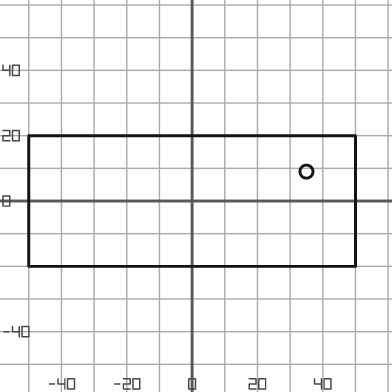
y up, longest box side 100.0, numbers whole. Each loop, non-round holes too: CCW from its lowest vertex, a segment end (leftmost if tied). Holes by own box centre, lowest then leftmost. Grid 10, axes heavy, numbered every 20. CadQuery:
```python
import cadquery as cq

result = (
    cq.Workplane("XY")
    .moveTo(-50.0, -20.0)
    .lineTo(50.0, -20.0)
    .lineTo(50.0, 20.0)
    .lineTo(-50.0, 20.0)
    .close()
    .moveTo(35.0, 9.0)
    .circle(2.0)
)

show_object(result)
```